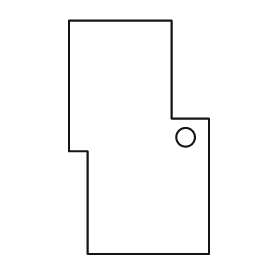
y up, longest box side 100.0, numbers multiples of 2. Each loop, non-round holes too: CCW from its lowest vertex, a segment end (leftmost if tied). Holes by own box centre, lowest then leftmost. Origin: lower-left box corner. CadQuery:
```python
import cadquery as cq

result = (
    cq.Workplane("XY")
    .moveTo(8.0, 0.0)
    .lineTo(60.0, 0.0)
    .lineTo(60.0, 58.0)
    .lineTo(44.0, 58.0)
    .lineTo(44.0, 100.0)
    .lineTo(0.0, 100.0)
    .lineTo(0.0, 44.0)
    .lineTo(8.0, 44.0)
    .close()
    .moveTo(50.0, 50.0)
    .circle(4.0)
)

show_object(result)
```